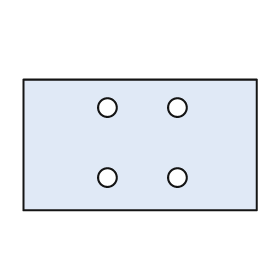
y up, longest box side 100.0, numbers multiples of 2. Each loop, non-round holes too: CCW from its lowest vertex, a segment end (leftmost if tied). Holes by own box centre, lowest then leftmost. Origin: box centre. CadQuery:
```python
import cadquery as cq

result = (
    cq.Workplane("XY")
    .moveTo(-50.0, -28.0)
    .lineTo(50.0, -28.0)
    .lineTo(50.0, 28.0)
    .lineTo(-50.0, 28.0)
    .close()
    .moveTo(-14.0, -14.0)
    .circle(4.0)
    .moveTo(16.0, -14.0)
    .circle(4.0)
    .moveTo(-14.0, 16.0)
    .circle(4.0)
    .moveTo(16.0, 16.0)
    .circle(4.0)
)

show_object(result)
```